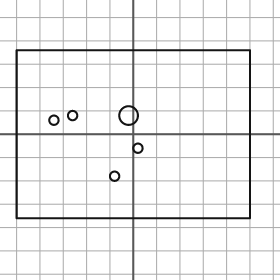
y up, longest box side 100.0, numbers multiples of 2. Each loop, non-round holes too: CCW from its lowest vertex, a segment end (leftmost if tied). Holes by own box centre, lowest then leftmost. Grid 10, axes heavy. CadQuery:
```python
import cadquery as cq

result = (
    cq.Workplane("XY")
    .moveTo(-50.0, -36.0)
    .lineTo(50.0, -36.0)
    .lineTo(50.0, 36.0)
    .lineTo(-50.0, 36.0)
    .close()
    .moveTo(-8.0, -18.0)
    .circle(2.0)
    .moveTo(2.0, -6.0)
    .circle(2.0)
    .moveTo(-34.0, 6.0)
    .circle(2.0)
    .moveTo(-26.0, 8.0)
    .circle(2.0)
    .moveTo(-2.0, 8.0)
    .circle(4.0)
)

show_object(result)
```